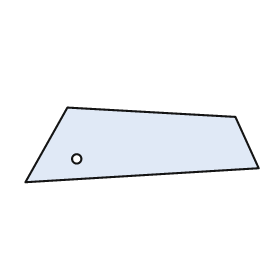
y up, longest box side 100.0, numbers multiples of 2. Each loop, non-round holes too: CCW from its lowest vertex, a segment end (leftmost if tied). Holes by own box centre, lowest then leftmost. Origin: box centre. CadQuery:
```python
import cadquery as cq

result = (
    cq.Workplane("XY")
    .moveTo(-50.0, -16.0)
    .lineTo(50.0, -10.0)
    .lineTo(40.0, 12.0)
    .lineTo(-32.0, 16.0)
    .close()
    .moveTo(-28.0, -6.0)
    .circle(2.0)
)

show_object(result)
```